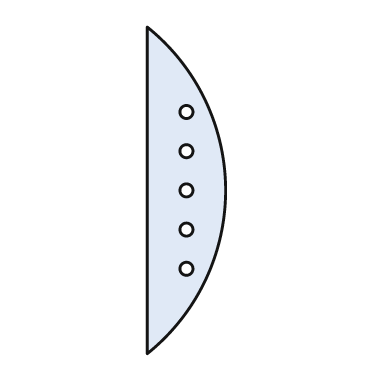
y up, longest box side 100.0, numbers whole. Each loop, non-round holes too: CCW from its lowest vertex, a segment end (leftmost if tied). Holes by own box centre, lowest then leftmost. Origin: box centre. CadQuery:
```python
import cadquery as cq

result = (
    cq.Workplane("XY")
    .moveTo(-12.0, -50.0)
    .threePointArc((12.0, 0.0), (-12.0, 50.0))
    .close()
    .moveTo(0.0, -24.0)
    .circle(2.0)
    .moveTo(0.0, -12.0)
    .circle(2.0)
    .moveTo(0.0, 0.0)
    .circle(2.0)
    .moveTo(0.0, 12.0)
    .circle(2.0)
    .moveTo(0.0, 24.0)
    .circle(2.0)
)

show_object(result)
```